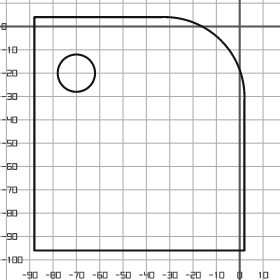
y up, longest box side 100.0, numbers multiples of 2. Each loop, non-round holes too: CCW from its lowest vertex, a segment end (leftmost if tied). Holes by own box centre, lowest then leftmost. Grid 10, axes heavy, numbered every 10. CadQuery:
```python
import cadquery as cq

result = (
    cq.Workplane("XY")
    .moveTo(-88.0, -96.0)
    .lineTo(2.0, -96.0)
    .lineTo(2.0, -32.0)
    .threePointArc((-8.0, -6.0), (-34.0, 4.0))
    .lineTo(-88.0, 4.0)
    .close()
    .moveTo(-70.0, -20.0)
    .circle(8.0)
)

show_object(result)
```